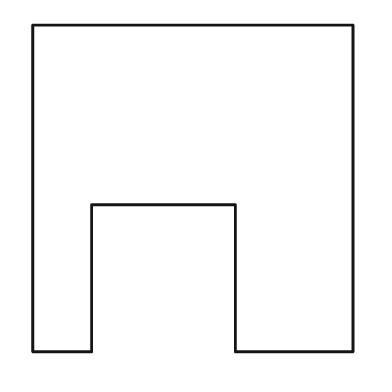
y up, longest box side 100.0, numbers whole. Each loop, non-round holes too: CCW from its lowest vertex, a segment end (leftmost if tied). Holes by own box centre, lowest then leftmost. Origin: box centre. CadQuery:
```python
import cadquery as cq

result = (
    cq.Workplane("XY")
    .moveTo(-49.0, -50.0)
    .lineTo(-31.0, -50.0)
    .lineTo(-31.0, -5.0)
    .lineTo(13.0, -5.0)
    .lineTo(13.0, -50.0)
    .lineTo(49.0, -50.0)
    .lineTo(49.0, 50.0)
    .lineTo(-49.0, 50.0)
    .close()
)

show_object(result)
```